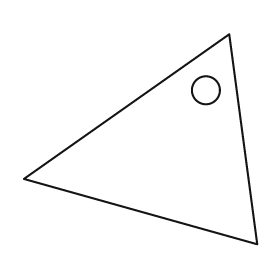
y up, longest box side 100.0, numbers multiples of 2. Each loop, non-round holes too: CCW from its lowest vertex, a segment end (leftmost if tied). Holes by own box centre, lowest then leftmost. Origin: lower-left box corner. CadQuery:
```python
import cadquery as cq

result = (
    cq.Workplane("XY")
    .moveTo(100.0, 0.0)
    .lineTo(88.0, 90.0)
    .lineTo(0.0, 28.0)
    .close()
    .moveTo(78.0, 66.0)
    .circle(6.0)
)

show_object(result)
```